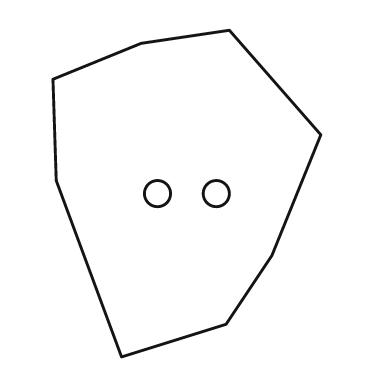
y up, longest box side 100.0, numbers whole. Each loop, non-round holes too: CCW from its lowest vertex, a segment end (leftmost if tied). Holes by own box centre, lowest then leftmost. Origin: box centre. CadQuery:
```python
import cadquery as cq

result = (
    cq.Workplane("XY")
    .moveTo(-20.0, -50.0)
    .lineTo(12.0, -40.0)
    .lineTo(26.0, -19.0)
    .lineTo(41.0, 18.0)
    .lineTo(13.0, 50.0)
    .lineTo(-14.0, 46.0)
    .lineTo(-41.0, 35.0)
    .lineTo(-40.0, 4.0)
    .close()
    .moveTo(-9.0, 0.0)
    .circle(4.0)
    .moveTo(9.0, 0.0)
    .circle(4.0)
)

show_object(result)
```